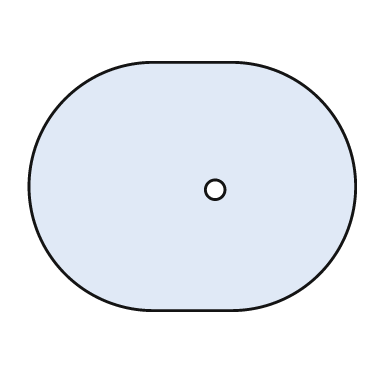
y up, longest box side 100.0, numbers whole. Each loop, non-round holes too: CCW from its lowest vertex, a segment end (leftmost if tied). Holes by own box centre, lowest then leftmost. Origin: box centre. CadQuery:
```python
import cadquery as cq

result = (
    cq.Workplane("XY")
    .moveTo(-12.0, -38.0)
    .lineTo(12.0, -38.0)
    .threePointArc((50.0, 0.0), (12.0, 38.0))
    .lineTo(-12.0, 38.0)
    .threePointArc((-50.0, 0.0), (-12.0, -38.0))
    .close()
    .moveTo(7.0, -1.0)
    .circle(3.0)
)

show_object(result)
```